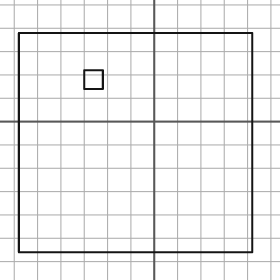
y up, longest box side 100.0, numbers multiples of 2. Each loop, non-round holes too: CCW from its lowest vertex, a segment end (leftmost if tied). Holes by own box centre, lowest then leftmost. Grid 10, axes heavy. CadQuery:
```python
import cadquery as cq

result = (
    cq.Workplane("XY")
    .moveTo(-58.0, -56.0)
    .lineTo(42.0, -56.0)
    .lineTo(42.0, 38.0)
    .lineTo(-58.0, 38.0)
    .close()
    .moveTo(-30.0, 14.0)
    .lineTo(-22.0, 14.0)
    .lineTo(-22.0, 22.0)
    .lineTo(-30.0, 22.0)
    .close()
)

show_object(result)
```